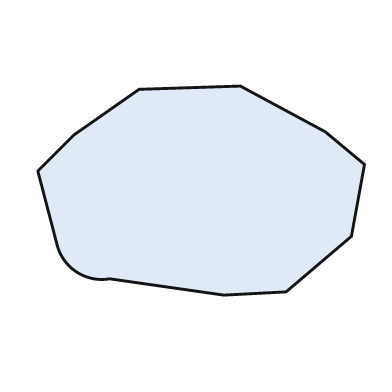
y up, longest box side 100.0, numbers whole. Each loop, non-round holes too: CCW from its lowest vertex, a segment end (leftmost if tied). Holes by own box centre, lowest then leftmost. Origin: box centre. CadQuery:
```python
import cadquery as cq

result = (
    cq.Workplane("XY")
    .moveTo(7.0, -32.0)
    .lineTo(26.0, -31.0)
    .lineTo(46.0, -14.0)
    .lineTo(50.0, 8.0)
    .lineTo(38.0, 18.0)
    .lineTo(12.0, 32.0)
    .lineTo(-19.0, 31.0)
    .lineTo(-39.0, 17.0)
    .lineTo(-50.0, 6.0)
    .lineTo(-44.0, -17.0)
    .threePointArc((-38.0, -25.0), (-28.0, -27.0))
    .close()
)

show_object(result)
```